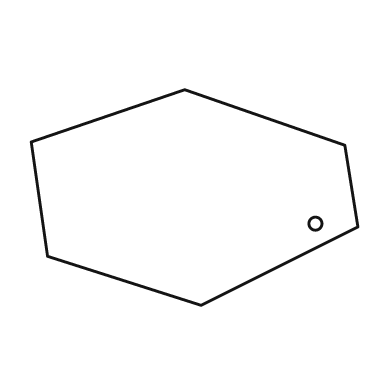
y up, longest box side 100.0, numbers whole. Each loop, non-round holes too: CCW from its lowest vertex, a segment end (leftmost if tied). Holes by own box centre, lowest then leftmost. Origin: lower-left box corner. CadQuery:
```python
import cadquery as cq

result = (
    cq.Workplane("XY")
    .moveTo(52.0, 0.0)
    .lineTo(100.0, 24.0)
    .lineTo(96.0, 49.0)
    .lineTo(47.0, 66.0)
    .lineTo(0.0, 50.0)
    .lineTo(5.0, 15.0)
    .close()
    .moveTo(87.0, 25.0)
    .circle(2.0)
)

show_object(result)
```